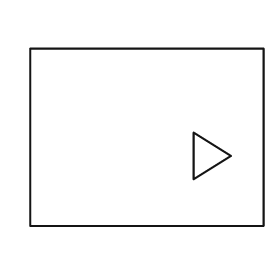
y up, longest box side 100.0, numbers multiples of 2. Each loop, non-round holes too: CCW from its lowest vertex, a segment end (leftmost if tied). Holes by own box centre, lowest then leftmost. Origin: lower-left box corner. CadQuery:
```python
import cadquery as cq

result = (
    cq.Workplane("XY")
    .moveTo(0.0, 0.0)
    .lineTo(100.0, 0.0)
    .lineTo(100.0, 76.0)
    .lineTo(0.0, 76.0)
    .close()
    .moveTo(70.0, 20.0)
    .lineTo(86.0, 30.0)
    .lineTo(70.0, 40.0)
    .close()
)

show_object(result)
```